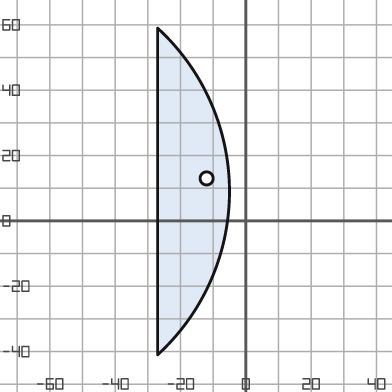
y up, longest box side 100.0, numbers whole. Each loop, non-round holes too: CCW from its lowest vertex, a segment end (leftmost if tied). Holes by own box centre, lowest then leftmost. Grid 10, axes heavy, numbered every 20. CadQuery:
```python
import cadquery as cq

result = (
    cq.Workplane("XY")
    .moveTo(-27.0, -41.0)
    .threePointArc((-5.0, 9.0), (-27.0, 59.0))
    .close()
    .moveTo(-12.0, 13.0)
    .circle(2.0)
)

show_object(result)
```